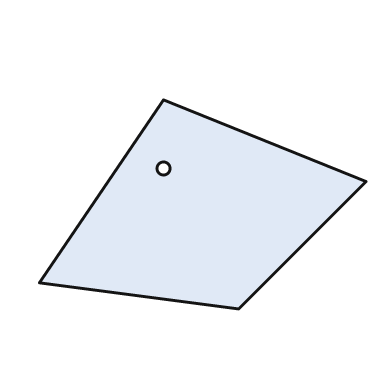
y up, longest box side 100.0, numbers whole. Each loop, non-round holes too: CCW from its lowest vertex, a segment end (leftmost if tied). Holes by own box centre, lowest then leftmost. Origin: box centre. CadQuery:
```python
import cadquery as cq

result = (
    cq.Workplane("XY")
    .moveTo(11.0, -32.0)
    .lineTo(50.0, 7.0)
    .lineTo(-12.0, 32.0)
    .lineTo(-50.0, -24.0)
    .close()
    .moveTo(-12.0, 11.0)
    .circle(2.0)
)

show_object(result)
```